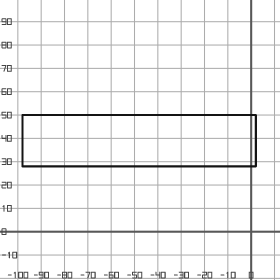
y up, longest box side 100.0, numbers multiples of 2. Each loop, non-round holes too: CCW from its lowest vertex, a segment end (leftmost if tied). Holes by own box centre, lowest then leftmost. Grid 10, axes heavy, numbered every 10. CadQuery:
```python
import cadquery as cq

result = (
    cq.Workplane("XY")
    .moveTo(-98.0, 28.0)
    .lineTo(2.0, 28.0)
    .lineTo(2.0, 50.0)
    .lineTo(-98.0, 50.0)
    .close()
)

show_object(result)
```